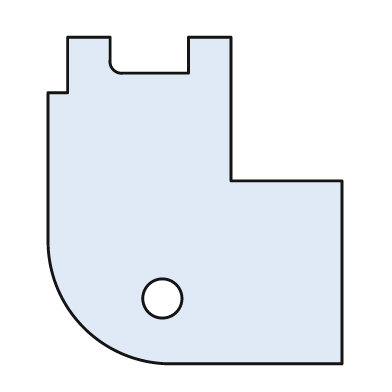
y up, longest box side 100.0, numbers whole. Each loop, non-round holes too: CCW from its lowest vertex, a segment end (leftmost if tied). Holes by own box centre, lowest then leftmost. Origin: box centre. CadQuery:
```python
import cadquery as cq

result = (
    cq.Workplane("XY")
    .moveTo(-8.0, -50.0)
    .lineTo(45.0, -50.0)
    .lineTo(45.0, 6.0)
    .lineTo(11.0, 6.0)
    .lineTo(11.0, 50.0)
    .lineTo(-2.0, 50.0)
    .lineTo(-2.0, 39.0)
    .lineTo(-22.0, 39.0)
    .threePointArc((-25.0, 40.0), (-26.0, 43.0))
    .lineTo(-26.0, 50.0)
    .lineTo(-39.0, 50.0)
    .lineTo(-39.0, 33.0)
    .lineTo(-45.0, 33.0)
    .lineTo(-45.0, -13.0)
    .threePointArc((-34.0, -39.0), (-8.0, -50.0))
    .close()
    .moveTo(-10.0, -30.0)
    .circle(6.0)
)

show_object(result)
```